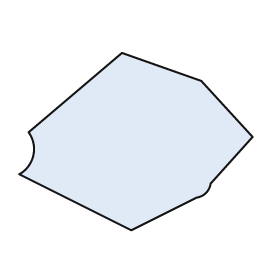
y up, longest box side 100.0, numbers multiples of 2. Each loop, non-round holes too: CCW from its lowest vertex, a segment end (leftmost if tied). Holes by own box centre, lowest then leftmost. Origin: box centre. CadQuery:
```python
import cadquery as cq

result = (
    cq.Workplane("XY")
    .moveTo(-2.0, -38.0)
    .lineTo(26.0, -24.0)
    .threePointArc((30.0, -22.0), (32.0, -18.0))
    .lineTo(50.0, 2.0)
    .lineTo(28.0, 26.0)
    .lineTo(-6.0, 38.0)
    .lineTo(-46.0, 4.0)
    .threePointArc((-44.0, -6.0), (-50.0, -14.0))
    .close()
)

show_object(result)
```